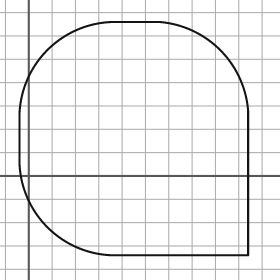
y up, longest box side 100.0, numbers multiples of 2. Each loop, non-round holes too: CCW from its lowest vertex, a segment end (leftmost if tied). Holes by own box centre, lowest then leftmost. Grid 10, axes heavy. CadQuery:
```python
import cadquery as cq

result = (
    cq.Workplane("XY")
    .moveTo(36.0, -34.0)
    .lineTo(94.0, -34.0)
    .lineTo(94.0, 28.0)
    .threePointArc((82.0, 54.0), (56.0, 66.0))
    .lineTo(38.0, 66.0)
    .threePointArc((8.0, 54.0), (-4.0, 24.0))
    .lineTo(-4.0, 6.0)
    .threePointArc((8.0, -22.0), (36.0, -34.0))
    .close()
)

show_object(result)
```